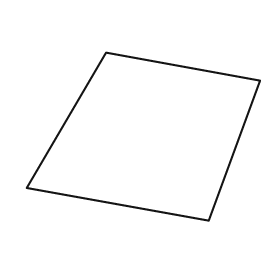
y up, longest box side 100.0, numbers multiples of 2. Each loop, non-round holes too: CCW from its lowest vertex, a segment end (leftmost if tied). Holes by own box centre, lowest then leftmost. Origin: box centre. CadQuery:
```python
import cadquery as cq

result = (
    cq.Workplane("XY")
    .moveTo(28.0, -36.0)
    .lineTo(50.0, 24.0)
    .lineTo(-16.0, 36.0)
    .lineTo(-50.0, -22.0)
    .close()
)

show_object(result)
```